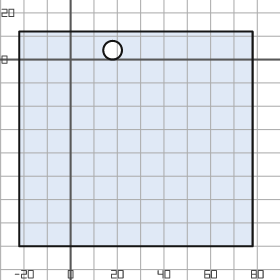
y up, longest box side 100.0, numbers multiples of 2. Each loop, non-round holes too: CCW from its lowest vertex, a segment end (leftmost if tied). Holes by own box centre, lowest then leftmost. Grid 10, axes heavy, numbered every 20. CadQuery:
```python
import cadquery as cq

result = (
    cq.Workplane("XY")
    .moveTo(-22.0, -80.0)
    .lineTo(78.0, -80.0)
    .lineTo(78.0, 12.0)
    .lineTo(-22.0, 12.0)
    .close()
    .moveTo(18.0, 4.0)
    .circle(4.0)
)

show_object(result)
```